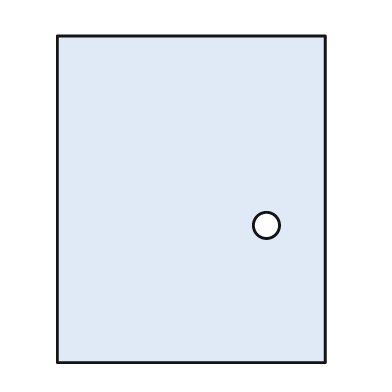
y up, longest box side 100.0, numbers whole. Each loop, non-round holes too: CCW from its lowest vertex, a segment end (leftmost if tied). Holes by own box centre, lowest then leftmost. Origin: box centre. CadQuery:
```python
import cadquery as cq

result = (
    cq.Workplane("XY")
    .moveTo(-41.0, -50.0)
    .lineTo(41.0, -50.0)
    .lineTo(41.0, 50.0)
    .lineTo(-41.0, 50.0)
    .close()
    .moveTo(23.0, -8.0)
    .circle(4.0)
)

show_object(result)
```